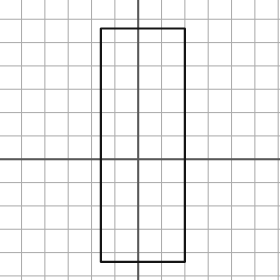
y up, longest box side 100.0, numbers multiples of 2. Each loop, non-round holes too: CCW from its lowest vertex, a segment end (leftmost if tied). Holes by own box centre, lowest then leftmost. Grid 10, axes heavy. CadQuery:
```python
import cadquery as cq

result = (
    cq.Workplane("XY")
    .moveTo(-16.0, -44.0)
    .lineTo(20.0, -44.0)
    .lineTo(20.0, 56.0)
    .lineTo(-16.0, 56.0)
    .close()
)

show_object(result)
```